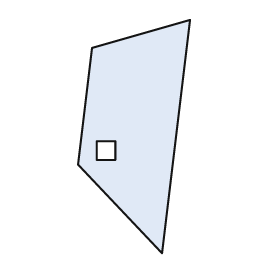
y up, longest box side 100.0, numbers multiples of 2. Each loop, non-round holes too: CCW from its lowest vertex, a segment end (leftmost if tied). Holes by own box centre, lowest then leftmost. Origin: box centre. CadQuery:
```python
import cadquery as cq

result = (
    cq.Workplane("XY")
    .moveTo(12.0, -50.0)
    .lineTo(24.0, 50.0)
    .lineTo(-18.0, 38.0)
    .lineTo(-24.0, -12.0)
    .close()
    .moveTo(-16.0, -10.0)
    .lineTo(-8.0, -10.0)
    .lineTo(-8.0, -2.0)
    .lineTo(-16.0, -2.0)
    .close()
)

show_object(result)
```